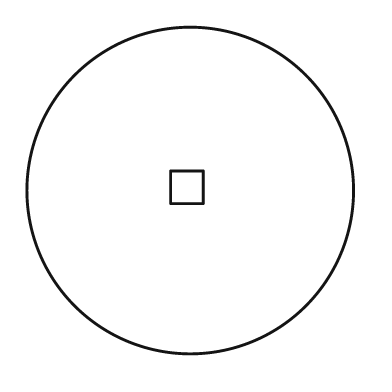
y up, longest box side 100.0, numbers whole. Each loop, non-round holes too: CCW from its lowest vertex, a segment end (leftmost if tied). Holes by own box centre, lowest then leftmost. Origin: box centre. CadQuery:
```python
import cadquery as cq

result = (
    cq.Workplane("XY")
    .moveTo(0.0, 0.0)
    .circle(50.0)
    .moveTo(-6.0, -4.0)
    .lineTo(4.0, -4.0)
    .lineTo(4.0, 6.0)
    .lineTo(-6.0, 6.0)
    .close()
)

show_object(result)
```